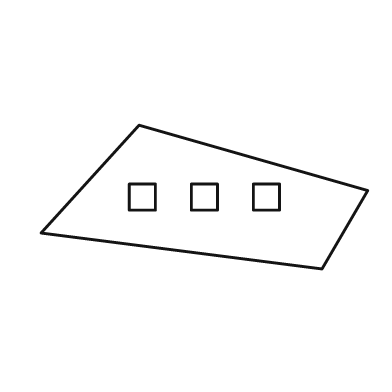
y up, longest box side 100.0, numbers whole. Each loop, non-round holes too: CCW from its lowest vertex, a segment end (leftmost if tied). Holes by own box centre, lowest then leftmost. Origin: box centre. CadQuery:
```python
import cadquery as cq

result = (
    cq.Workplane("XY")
    .moveTo(36.0, -22.0)
    .lineTo(50.0, 2.0)
    .lineTo(-20.0, 22.0)
    .lineTo(-50.0, -11.0)
    .close()
    .moveTo(-23.0, -4.0)
    .lineTo(-15.0, -4.0)
    .lineTo(-15.0, 4.0)
    .lineTo(-23.0, 4.0)
    .close()
    .moveTo(-4.0, -4.0)
    .lineTo(4.0, -4.0)
    .lineTo(4.0, 4.0)
    .lineTo(-4.0, 4.0)
    .close()
    .moveTo(15.0, -4.0)
    .lineTo(23.0, -4.0)
    .lineTo(23.0, 4.0)
    .lineTo(15.0, 4.0)
    .close()
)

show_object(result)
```